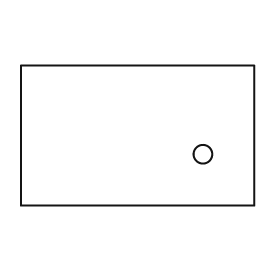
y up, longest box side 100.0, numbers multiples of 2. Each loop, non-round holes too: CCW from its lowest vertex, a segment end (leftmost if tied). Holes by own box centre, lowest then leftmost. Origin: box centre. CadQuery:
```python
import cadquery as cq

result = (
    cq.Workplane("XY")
    .moveTo(-50.0, -30.0)
    .lineTo(50.0, -30.0)
    .lineTo(50.0, 30.0)
    .lineTo(-50.0, 30.0)
    .close()
    .moveTo(28.0, -8.0)
    .circle(4.0)
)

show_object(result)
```